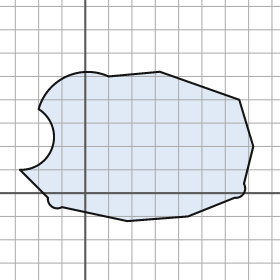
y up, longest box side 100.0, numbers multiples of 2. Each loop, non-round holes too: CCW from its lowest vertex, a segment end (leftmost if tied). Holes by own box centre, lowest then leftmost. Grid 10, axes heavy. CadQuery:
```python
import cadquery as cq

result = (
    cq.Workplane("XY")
    .moveTo(18.0, -12.0)
    .lineTo(44.0, -10.0)
    .lineTo(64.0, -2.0)
    .threePointArc((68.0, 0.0), (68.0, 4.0))
    .lineTo(72.0, 20.0)
    .lineTo(66.0, 40.0)
    .lineTo(32.0, 52.0)
    .lineTo(10.0, 50.0)
    .threePointArc((-8.0, 50.0), (-20.0, 36.0))
    .threePointArc((-14.0, 20.0), (-28.0, 10.0))
    .lineTo(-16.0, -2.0)
    .threePointArc((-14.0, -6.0), (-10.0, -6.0))
    .close()
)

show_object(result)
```